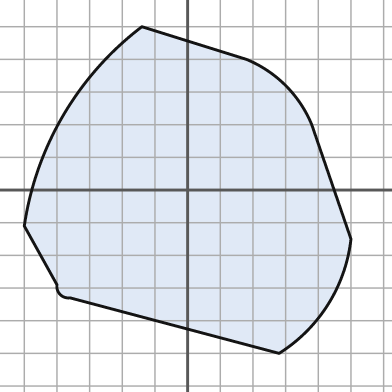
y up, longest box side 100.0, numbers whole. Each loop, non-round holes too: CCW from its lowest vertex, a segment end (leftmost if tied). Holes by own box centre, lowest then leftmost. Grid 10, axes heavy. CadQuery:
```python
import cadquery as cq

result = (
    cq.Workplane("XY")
    .moveTo(28.0, -50.0)
    .threePointArc((43.0, -35.0), (50.0, -15.0))
    .lineTo(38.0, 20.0)
    .threePointArc((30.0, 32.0), (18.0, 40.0))
    .lineTo(-14.0, 50.0)
    .threePointArc((-38.0, 23.0), (-50.0, -11.0))
    .lineTo(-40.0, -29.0)
    .threePointArc((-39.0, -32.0), (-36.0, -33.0))
    .close()
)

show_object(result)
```